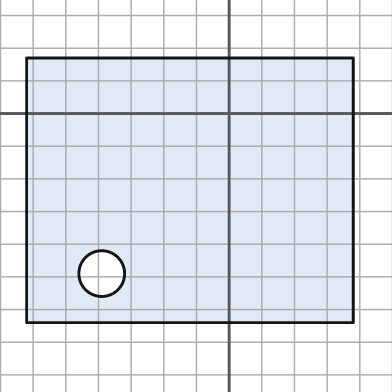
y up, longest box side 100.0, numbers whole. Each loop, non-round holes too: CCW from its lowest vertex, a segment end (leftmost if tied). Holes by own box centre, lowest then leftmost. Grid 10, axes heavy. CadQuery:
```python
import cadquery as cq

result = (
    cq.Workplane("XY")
    .moveTo(-62.0, -64.0)
    .lineTo(38.0, -64.0)
    .lineTo(38.0, 17.0)
    .lineTo(-62.0, 17.0)
    .close()
    .moveTo(-39.0, -49.0)
    .circle(7.0)
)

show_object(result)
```